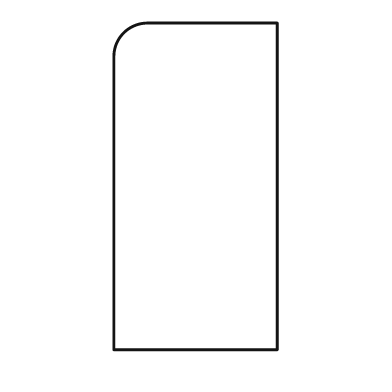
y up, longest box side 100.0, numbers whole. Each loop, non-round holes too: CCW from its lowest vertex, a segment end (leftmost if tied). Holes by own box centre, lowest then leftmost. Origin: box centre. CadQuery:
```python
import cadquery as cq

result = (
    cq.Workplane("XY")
    .moveTo(-25.0, -50.0)
    .lineTo(25.0, -50.0)
    .lineTo(25.0, 50.0)
    .lineTo(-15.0, 50.0)
    .threePointArc((-22.0, 47.0), (-25.0, 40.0))
    .close()
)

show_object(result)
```